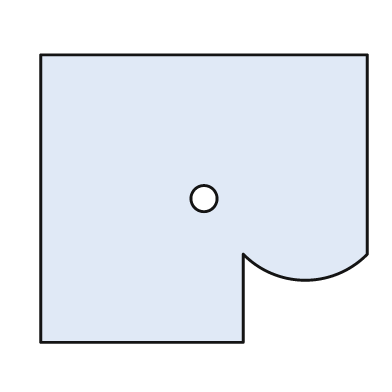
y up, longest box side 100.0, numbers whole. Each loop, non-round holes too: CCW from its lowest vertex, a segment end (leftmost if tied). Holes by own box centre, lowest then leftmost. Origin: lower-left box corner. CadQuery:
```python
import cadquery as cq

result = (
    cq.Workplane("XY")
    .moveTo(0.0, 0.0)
    .lineTo(62.0, 0.0)
    .lineTo(62.0, 27.0)
    .threePointArc((81.0, 19.0), (100.0, 27.0))
    .lineTo(100.0, 88.0)
    .lineTo(0.0, 88.0)
    .close()
    .moveTo(50.0, 44.0)
    .circle(4.0)
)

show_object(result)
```